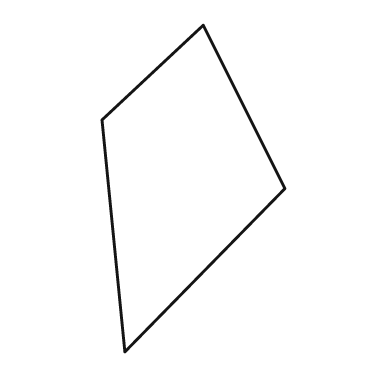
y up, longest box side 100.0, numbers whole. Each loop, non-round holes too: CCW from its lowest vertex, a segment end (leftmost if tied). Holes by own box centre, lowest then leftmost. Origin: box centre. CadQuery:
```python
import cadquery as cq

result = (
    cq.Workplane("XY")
    .moveTo(-21.0, -50.0)
    .lineTo(28.0, 0.0)
    .lineTo(3.0, 50.0)
    .lineTo(-28.0, 21.0)
    .close()
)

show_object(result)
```